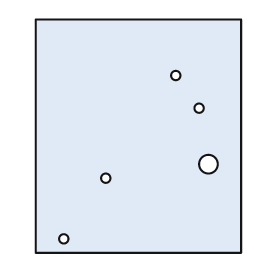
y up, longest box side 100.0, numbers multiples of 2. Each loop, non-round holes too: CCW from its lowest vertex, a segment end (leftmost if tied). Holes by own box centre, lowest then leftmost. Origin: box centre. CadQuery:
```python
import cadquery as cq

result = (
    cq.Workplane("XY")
    .moveTo(-44.0, -50.0)
    .lineTo(44.0, -50.0)
    .lineTo(44.0, 50.0)
    .lineTo(-44.0, 50.0)
    .close()
    .moveTo(-32.0, -44.0)
    .circle(2.0)
    .moveTo(-14.0, -18.0)
    .circle(2.0)
    .moveTo(30.0, -12.0)
    .circle(4.0)
    .moveTo(26.0, 12.0)
    .circle(2.0)
    .moveTo(16.0, 26.0)
    .circle(2.0)
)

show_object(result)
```